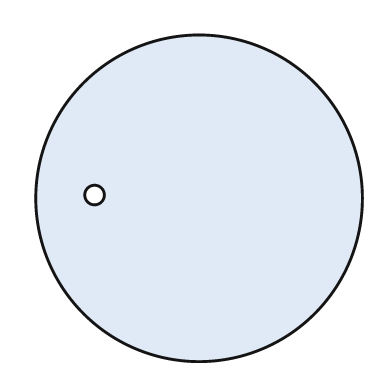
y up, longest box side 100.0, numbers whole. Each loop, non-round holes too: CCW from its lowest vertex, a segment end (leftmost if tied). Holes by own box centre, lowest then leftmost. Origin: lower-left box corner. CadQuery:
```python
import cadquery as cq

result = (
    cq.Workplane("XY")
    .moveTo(50.0, 50.0)
    .circle(50.0)
    .moveTo(18.0, 51.0)
    .circle(3.0)
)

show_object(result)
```